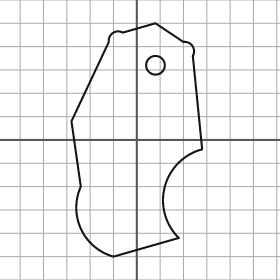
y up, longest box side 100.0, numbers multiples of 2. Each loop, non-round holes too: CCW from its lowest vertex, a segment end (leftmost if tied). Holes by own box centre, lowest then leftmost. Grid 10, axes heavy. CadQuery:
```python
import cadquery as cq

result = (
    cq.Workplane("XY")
    .moveTo(-10.0, -50.0)
    .lineTo(18.0, -42.0)
    .threePointArc((12.0, -20.0), (28.0, -4.0))
    .lineTo(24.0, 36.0)
    .threePointArc((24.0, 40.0), (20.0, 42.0))
    .lineTo(8.0, 50.0)
    .lineTo(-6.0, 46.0)
    .threePointArc((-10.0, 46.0), (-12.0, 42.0))
    .lineTo(-28.0, 8.0)
    .lineTo(-24.0, -20.0)
    .threePointArc((-24.0, -38.0), (-10.0, -50.0))
    .close()
    .moveTo(8.0, 32.0)
    .circle(4.0)
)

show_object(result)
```